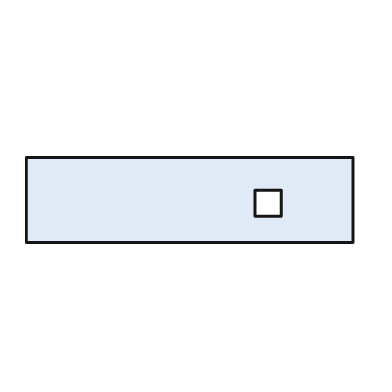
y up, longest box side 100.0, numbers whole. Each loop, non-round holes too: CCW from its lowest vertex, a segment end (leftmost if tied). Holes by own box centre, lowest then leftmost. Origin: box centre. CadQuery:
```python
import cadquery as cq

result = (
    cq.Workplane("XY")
    .moveTo(-50.0, -13.0)
    .lineTo(50.0, -13.0)
    .lineTo(50.0, 13.0)
    .lineTo(-50.0, 13.0)
    .close()
    .moveTo(20.0, -5.0)
    .lineTo(28.0, -5.0)
    .lineTo(28.0, 3.0)
    .lineTo(20.0, 3.0)
    .close()
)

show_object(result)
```